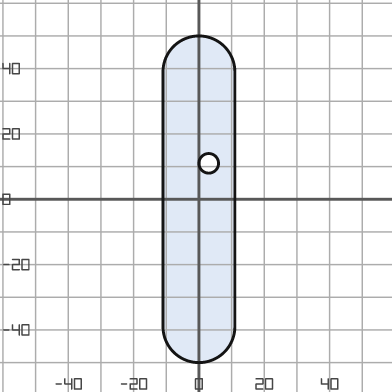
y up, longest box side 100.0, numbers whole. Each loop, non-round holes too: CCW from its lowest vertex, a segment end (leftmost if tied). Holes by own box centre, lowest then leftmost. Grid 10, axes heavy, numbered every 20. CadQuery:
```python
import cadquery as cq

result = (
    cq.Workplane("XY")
    .moveTo(-11.0, -39.0)
    .threePointArc((0.0, -50.0), (11.0, -39.0))
    .lineTo(11.0, 39.0)
    .threePointArc((0.0, 50.0), (-11.0, 39.0))
    .close()
    .moveTo(3.0, 11.0)
    .circle(3.0)
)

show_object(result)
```